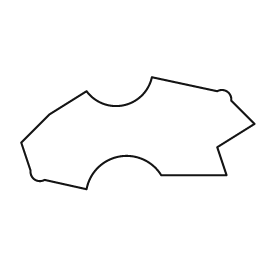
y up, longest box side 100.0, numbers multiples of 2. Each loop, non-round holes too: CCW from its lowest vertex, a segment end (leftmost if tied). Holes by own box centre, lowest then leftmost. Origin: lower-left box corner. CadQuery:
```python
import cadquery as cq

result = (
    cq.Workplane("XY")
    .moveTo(28.0, 0.0)
    .threePointArc((42.0, 14.0), (60.0, 6.0))
    .lineTo(88.0, 6.0)
    .lineTo(84.0, 18.0)
    .lineTo(100.0, 28.0)
    .lineTo(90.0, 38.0)
    .threePointArc((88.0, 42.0), (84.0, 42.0))
    .lineTo(56.0, 48.0)
    .threePointArc((44.0, 36.0), (28.0, 42.0))
    .lineTo(12.0, 32.0)
    .lineTo(0.0, 20.0)
    .lineTo(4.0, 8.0)
    .threePointArc((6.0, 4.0), (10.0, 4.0))
    .close()
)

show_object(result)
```